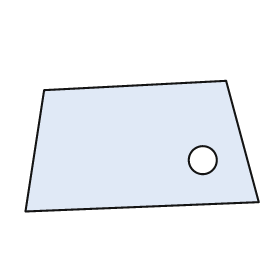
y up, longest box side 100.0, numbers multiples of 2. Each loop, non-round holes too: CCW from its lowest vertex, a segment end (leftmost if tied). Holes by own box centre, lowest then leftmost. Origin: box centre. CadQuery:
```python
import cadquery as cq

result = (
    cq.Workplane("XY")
    .moveTo(-50.0, -28.0)
    .lineTo(50.0, -24.0)
    .lineTo(36.0, 28.0)
    .lineTo(-42.0, 24.0)
    .close()
    .moveTo(26.0, -6.0)
    .circle(6.0)
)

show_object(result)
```